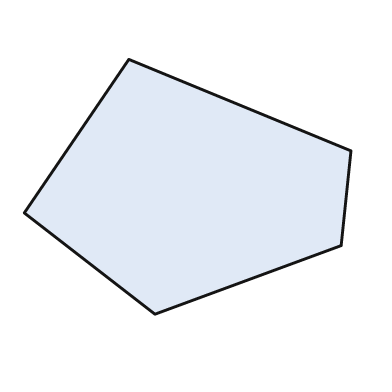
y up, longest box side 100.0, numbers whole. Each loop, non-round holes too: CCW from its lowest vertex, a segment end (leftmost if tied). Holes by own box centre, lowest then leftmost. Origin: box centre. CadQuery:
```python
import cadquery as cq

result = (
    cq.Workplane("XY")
    .moveTo(-10.0, -39.0)
    .lineTo(47.0, -18.0)
    .lineTo(50.0, 11.0)
    .lineTo(-18.0, 39.0)
    .lineTo(-50.0, -8.0)
    .close()
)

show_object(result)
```